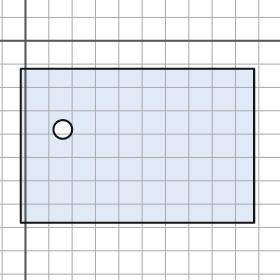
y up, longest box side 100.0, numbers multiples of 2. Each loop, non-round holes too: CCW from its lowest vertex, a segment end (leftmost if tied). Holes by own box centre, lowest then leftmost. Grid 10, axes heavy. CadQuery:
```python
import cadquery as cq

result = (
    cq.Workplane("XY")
    .moveTo(-2.0, -78.0)
    .lineTo(98.0, -78.0)
    .lineTo(98.0, -12.0)
    .lineTo(-2.0, -12.0)
    .close()
    .moveTo(16.0, -38.0)
    .circle(4.0)
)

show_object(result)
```